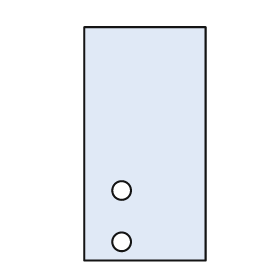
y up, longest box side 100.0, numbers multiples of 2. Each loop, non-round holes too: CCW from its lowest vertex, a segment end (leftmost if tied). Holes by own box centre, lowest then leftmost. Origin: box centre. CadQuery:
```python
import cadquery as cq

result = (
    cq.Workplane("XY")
    .moveTo(-26.0, -50.0)
    .lineTo(26.0, -50.0)
    .lineTo(26.0, 50.0)
    .lineTo(-26.0, 50.0)
    .close()
    .moveTo(-10.0, -42.0)
    .circle(4.0)
    .moveTo(-10.0, -20.0)
    .circle(4.0)
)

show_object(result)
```